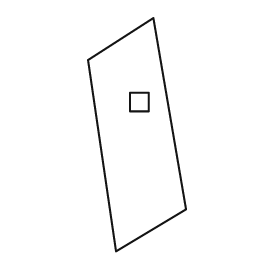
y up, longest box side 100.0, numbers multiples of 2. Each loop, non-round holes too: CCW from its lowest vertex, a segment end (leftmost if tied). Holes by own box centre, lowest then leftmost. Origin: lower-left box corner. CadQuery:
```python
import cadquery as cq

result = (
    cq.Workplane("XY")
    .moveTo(12.0, 0.0)
    .lineTo(42.0, 18.0)
    .lineTo(28.0, 100.0)
    .lineTo(0.0, 82.0)
    .close()
    .moveTo(18.0, 60.0)
    .lineTo(26.0, 60.0)
    .lineTo(26.0, 68.0)
    .lineTo(18.0, 68.0)
    .close()
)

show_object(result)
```